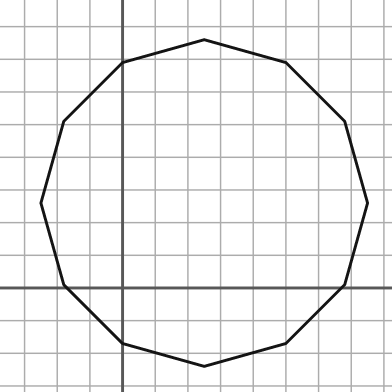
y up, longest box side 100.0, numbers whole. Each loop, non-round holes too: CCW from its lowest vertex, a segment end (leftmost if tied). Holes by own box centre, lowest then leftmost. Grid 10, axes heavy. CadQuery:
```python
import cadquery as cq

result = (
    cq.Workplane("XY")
    .moveTo(25.0, -24.0)
    .lineTo(50.0, -17.0)
    .lineTo(68.0, 1.0)
    .lineTo(75.0, 26.0)
    .lineTo(68.0, 51.0)
    .lineTo(50.0, 69.0)
    .lineTo(25.0, 76.0)
    .lineTo(0.0, 69.0)
    .lineTo(-18.0, 51.0)
    .lineTo(-25.0, 26.0)
    .lineTo(-18.0, 1.0)
    .lineTo(0.0, -17.0)
    .close()
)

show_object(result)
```